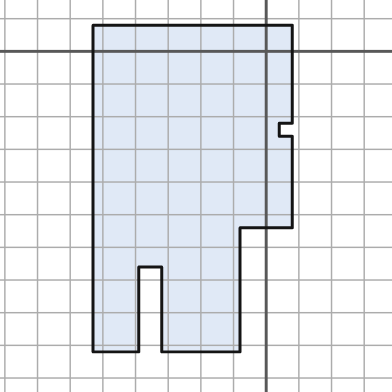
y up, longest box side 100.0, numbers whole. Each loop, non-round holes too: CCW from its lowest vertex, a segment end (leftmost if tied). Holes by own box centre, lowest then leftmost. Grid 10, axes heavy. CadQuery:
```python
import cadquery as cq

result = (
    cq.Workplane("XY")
    .moveTo(-53.0, -92.0)
    .lineTo(-39.0, -92.0)
    .lineTo(-39.0, -66.0)
    .lineTo(-32.0, -66.0)
    .lineTo(-32.0, -92.0)
    .lineTo(-8.0, -92.0)
    .lineTo(-8.0, -54.0)
    .lineTo(8.0, -54.0)
    .lineTo(8.0, -26.0)
    .lineTo(4.0, -26.0)
    .lineTo(4.0, -22.0)
    .lineTo(8.0, -22.0)
    .lineTo(8.0, 8.0)
    .lineTo(-53.0, 8.0)
    .close()
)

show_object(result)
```